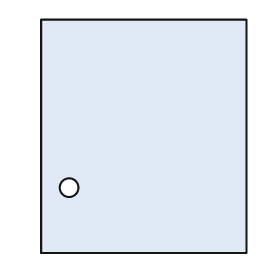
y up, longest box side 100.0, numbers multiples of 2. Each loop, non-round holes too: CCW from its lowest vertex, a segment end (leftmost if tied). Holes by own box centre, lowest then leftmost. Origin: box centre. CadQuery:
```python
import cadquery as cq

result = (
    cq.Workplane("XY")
    .moveTo(-44.0, -50.0)
    .lineTo(44.0, -50.0)
    .lineTo(44.0, 50.0)
    .lineTo(-44.0, 50.0)
    .close()
    .moveTo(-32.0, -22.0)
    .circle(4.0)
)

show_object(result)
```